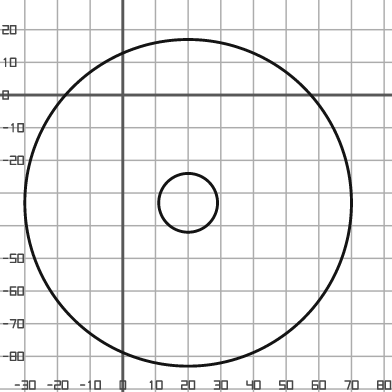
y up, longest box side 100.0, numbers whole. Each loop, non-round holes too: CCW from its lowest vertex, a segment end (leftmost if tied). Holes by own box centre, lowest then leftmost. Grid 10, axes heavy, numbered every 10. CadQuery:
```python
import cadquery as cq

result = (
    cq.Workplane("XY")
    .moveTo(20.0, -33.0)
    .circle(50.0)
    .moveTo(20.0, -33.0)
    .circle(9.0)
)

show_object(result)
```